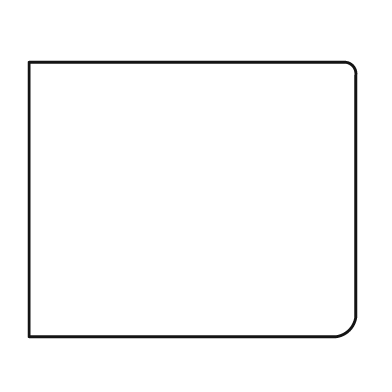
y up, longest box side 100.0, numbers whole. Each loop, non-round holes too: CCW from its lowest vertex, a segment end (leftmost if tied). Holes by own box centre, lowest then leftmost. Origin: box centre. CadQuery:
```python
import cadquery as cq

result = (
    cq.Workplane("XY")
    .moveTo(-50.0, -42.0)
    .lineTo(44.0, -42.0)
    .threePointArc((48.0, -40.0), (50.0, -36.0))
    .lineTo(50.0, 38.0)
    .threePointArc((49.0, 41.0), (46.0, 42.0))
    .lineTo(-50.0, 42.0)
    .close()
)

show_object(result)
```